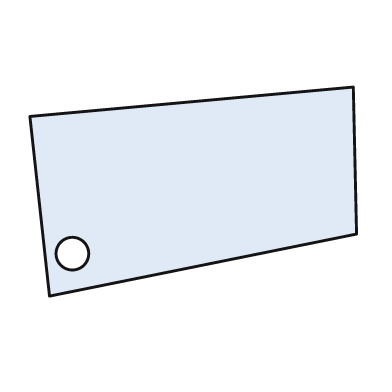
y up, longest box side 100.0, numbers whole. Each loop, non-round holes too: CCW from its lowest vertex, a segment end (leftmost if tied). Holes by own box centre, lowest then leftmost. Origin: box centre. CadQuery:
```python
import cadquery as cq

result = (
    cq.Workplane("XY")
    .moveTo(-44.0, -32.0)
    .lineTo(50.0, -13.0)
    .lineTo(49.0, 32.0)
    .lineTo(-50.0, 23.0)
    .close()
    .moveTo(-37.0, -19.0)
    .circle(5.0)
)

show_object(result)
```